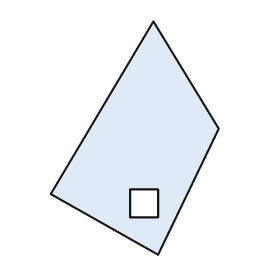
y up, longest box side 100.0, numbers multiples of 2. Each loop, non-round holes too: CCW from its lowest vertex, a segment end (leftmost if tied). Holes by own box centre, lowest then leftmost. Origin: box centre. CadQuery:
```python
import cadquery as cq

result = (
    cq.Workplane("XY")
    .moveTo(10.0, -50.0)
    .lineTo(36.0, 4.0)
    .lineTo(8.0, 50.0)
    .lineTo(-36.0, -24.0)
    .close()
    .moveTo(-2.0, -34.0)
    .lineTo(10.0, -34.0)
    .lineTo(10.0, -22.0)
    .lineTo(-2.0, -22.0)
    .close()
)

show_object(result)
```